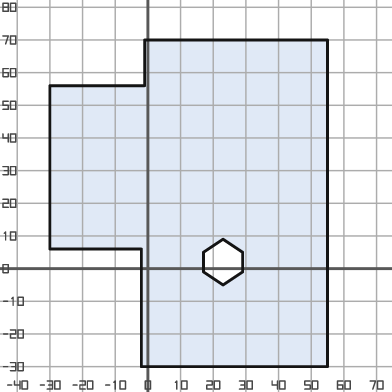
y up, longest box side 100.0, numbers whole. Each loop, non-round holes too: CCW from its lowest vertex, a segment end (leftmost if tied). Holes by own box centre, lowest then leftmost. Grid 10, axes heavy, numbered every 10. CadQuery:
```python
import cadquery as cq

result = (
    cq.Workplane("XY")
    .moveTo(-2.0, -30.0)
    .lineTo(55.0, -30.0)
    .lineTo(55.0, 70.0)
    .lineTo(-1.0, 70.0)
    .lineTo(-1.0, 56.0)
    .lineTo(-30.0, 56.0)
    .lineTo(-30.0, 6.0)
    .lineTo(-2.0, 6.0)
    .close()
    .moveTo(23.0, -5.0)
    .lineTo(29.0, -1.0)
    .lineTo(29.0, 5.0)
    .lineTo(23.0, 9.0)
    .lineTo(17.0, 5.0)
    .lineTo(17.0, -1.0)
    .close()
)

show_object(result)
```